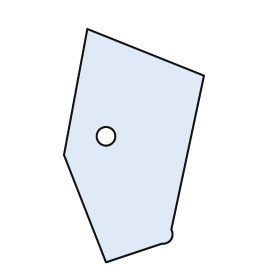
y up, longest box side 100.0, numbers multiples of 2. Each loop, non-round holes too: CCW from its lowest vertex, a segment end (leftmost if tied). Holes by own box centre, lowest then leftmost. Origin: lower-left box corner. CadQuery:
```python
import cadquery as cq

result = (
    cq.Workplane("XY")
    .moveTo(18.0, 0.0)
    .lineTo(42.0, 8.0)
    .threePointArc((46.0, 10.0), (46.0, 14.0))
    .lineTo(60.0, 80.0)
    .lineTo(10.0, 100.0)
    .lineTo(0.0, 46.0)
    .close()
    .moveTo(18.0, 54.0)
    .circle(4.0)
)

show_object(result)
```